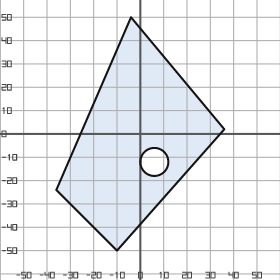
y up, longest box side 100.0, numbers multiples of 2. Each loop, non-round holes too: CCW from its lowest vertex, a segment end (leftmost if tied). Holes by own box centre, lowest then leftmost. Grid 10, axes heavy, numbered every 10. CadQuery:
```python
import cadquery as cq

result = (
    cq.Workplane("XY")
    .moveTo(-10.0, -50.0)
    .lineTo(36.0, 2.0)
    .lineTo(-4.0, 50.0)
    .lineTo(-36.0, -24.0)
    .close()
    .moveTo(6.0, -12.0)
    .circle(6.0)
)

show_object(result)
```